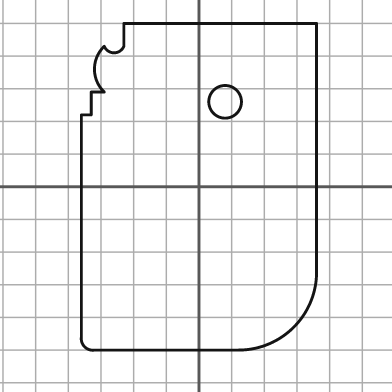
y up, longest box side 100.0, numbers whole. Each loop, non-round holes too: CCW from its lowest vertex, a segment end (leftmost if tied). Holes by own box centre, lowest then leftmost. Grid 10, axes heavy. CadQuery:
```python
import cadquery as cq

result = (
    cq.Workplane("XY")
    .moveTo(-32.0, -50.0)
    .lineTo(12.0, -50.0)
    .threePointArc((29.0, -43.0), (36.0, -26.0))
    .lineTo(36.0, 50.0)
    .lineTo(-23.0, 50.0)
    .lineTo(-23.0, 43.0)
    .threePointArc((-26.0, 41.0), (-29.0, 43.0))
    .threePointArc((-32.0, 36.0), (-29.0, 29.0))
    .lineTo(-33.0, 29.0)
    .lineTo(-33.0, 22.0)
    .lineTo(-36.0, 22.0)
    .lineTo(-36.0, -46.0)
    .threePointArc((-35.0, -49.0), (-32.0, -50.0))
    .close()
    .moveTo(8.0, 26.0)
    .circle(5.0)
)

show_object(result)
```